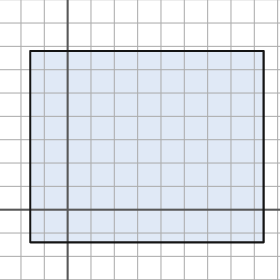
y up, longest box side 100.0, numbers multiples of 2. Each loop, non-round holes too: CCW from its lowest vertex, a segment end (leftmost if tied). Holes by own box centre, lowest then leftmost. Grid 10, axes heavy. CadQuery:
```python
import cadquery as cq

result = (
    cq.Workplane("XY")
    .moveTo(-16.0, -14.0)
    .lineTo(84.0, -14.0)
    .lineTo(84.0, 68.0)
    .lineTo(-16.0, 68.0)
    .close()
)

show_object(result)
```